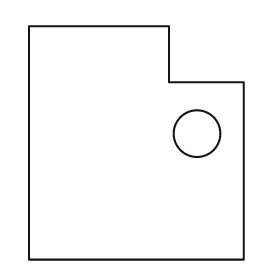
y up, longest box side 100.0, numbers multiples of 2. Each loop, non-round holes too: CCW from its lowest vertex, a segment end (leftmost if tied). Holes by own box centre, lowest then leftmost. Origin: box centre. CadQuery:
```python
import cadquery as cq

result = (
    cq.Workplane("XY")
    .moveTo(-46.0, -50.0)
    .lineTo(46.0, -50.0)
    .lineTo(46.0, 26.0)
    .lineTo(14.0, 26.0)
    .lineTo(14.0, 50.0)
    .lineTo(-46.0, 50.0)
    .close()
    .moveTo(26.0, 4.0)
    .circle(10.0)
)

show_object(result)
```